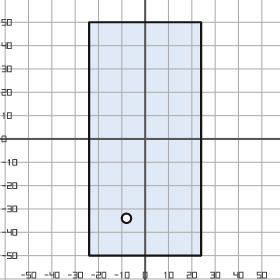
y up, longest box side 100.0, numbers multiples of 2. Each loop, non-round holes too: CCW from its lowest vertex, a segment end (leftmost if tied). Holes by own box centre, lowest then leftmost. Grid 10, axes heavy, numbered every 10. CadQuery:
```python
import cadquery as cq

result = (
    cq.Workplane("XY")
    .moveTo(-24.0, -50.0)
    .lineTo(24.0, -50.0)
    .lineTo(24.0, 50.0)
    .lineTo(-24.0, 50.0)
    .close()
    .moveTo(-8.0, -34.0)
    .circle(2.0)
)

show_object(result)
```